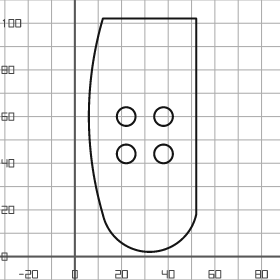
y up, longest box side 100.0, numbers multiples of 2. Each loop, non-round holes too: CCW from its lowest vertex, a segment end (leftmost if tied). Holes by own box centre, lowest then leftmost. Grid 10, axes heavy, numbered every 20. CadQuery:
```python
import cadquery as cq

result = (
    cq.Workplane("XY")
    .moveTo(12.0, 18.0)
    .threePointArc((32.0, 2.0), (52.0, 18.0))
    .lineTo(52.0, 102.0)
    .lineTo(12.0, 102.0)
    .threePointArc((6.0, 60.0), (12.0, 18.0))
    .close()
    .moveTo(22.0, 44.0)
    .circle(4.0)
    .moveTo(38.0, 44.0)
    .circle(4.0)
    .moveTo(22.0, 60.0)
    .circle(4.0)
    .moveTo(38.0, 60.0)
    .circle(4.0)
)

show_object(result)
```